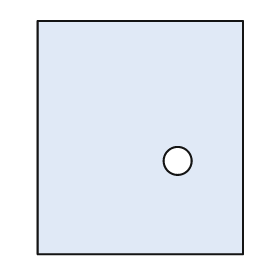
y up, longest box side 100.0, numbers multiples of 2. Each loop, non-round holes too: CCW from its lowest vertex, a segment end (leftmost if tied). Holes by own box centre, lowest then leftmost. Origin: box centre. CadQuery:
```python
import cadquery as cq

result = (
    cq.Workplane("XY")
    .moveTo(-44.0, -50.0)
    .lineTo(44.0, -50.0)
    .lineTo(44.0, 50.0)
    .lineTo(-44.0, 50.0)
    .close()
    .moveTo(16.0, -10.0)
    .circle(6.0)
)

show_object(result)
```